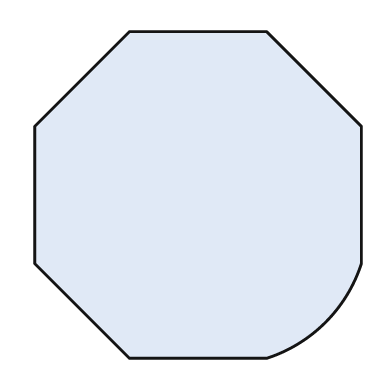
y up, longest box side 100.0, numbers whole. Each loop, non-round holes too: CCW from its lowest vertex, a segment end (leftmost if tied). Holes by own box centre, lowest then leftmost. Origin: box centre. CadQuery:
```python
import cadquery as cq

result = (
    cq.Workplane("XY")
    .moveTo(-21.0, -50.0)
    .lineTo(21.0, -50.0)
    .threePointArc((39.0, -39.0), (50.0, -21.0))
    .lineTo(50.0, 21.0)
    .lineTo(21.0, 50.0)
    .lineTo(-21.0, 50.0)
    .lineTo(-50.0, 21.0)
    .lineTo(-50.0, -21.0)
    .close()
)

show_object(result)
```